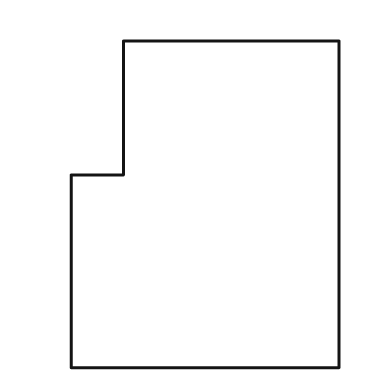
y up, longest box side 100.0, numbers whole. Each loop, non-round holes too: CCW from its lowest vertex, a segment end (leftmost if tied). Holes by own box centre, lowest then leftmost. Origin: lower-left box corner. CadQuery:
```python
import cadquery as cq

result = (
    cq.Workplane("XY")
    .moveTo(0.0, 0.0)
    .lineTo(82.0, 0.0)
    .lineTo(82.0, 100.0)
    .lineTo(16.0, 100.0)
    .lineTo(16.0, 59.0)
    .lineTo(0.0, 59.0)
    .close()
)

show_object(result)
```